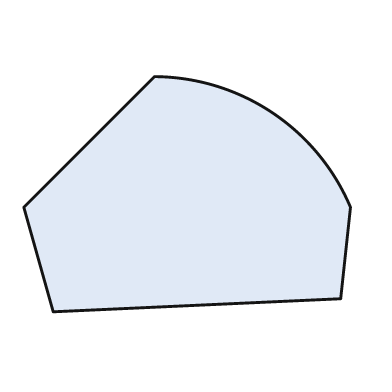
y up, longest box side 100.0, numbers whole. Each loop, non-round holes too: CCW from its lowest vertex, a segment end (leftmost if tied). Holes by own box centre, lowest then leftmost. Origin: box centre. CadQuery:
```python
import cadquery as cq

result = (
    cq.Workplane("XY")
    .moveTo(-41.0, -36.0)
    .lineTo(47.0, -32.0)
    .lineTo(50.0, -4.0)
    .threePointArc((26.0, 25.0), (-10.0, 36.0))
    .lineTo(-50.0, -4.0)
    .close()
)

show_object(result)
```